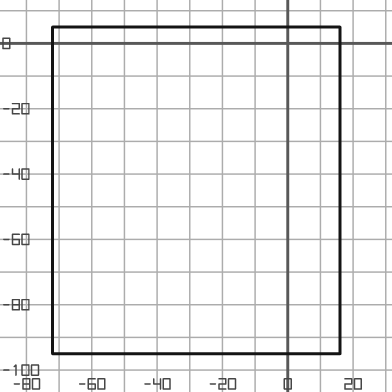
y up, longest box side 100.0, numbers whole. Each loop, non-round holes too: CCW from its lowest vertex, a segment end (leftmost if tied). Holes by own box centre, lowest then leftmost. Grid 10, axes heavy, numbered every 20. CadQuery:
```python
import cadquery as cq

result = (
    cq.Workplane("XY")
    .moveTo(-72.0, -95.0)
    .lineTo(16.0, -95.0)
    .lineTo(16.0, 5.0)
    .lineTo(-72.0, 5.0)
    .close()
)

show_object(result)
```